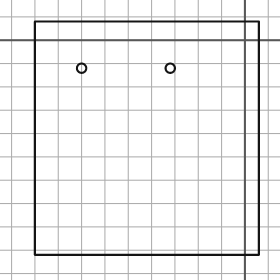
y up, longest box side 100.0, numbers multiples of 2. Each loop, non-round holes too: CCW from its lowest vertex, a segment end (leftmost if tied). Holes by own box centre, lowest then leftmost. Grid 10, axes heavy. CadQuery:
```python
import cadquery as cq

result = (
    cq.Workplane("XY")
    .moveTo(-90.0, -92.0)
    .lineTo(6.0, -92.0)
    .lineTo(6.0, 8.0)
    .lineTo(-90.0, 8.0)
    .close()
    .moveTo(-70.0, -12.0)
    .circle(2.0)
    .moveTo(-32.0, -12.0)
    .circle(2.0)
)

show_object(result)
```